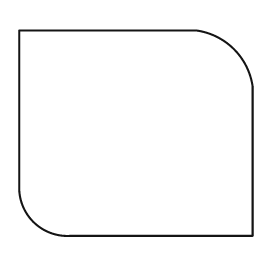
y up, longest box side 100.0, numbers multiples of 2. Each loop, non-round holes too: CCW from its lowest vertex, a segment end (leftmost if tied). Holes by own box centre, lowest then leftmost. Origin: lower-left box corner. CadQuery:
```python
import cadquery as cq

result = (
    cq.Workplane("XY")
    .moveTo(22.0, 0.0)
    .lineTo(100.0, 0.0)
    .lineTo(100.0, 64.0)
    .threePointArc((92.0, 80.0), (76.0, 88.0))
    .lineTo(0.0, 88.0)
    .lineTo(0.0, 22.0)
    .threePointArc((6.0, 6.0), (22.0, 0.0))
    .close()
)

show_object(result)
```